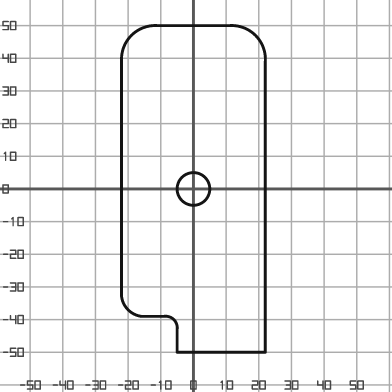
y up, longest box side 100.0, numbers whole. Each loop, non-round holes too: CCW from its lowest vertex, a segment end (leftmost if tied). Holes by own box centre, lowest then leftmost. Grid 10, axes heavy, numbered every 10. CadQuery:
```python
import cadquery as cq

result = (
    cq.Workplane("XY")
    .moveTo(-5.0, -50.0)
    .lineTo(22.0, -50.0)
    .lineTo(22.0, 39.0)
    .threePointArc((19.0, 47.0), (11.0, 50.0))
    .lineTo(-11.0, 50.0)
    .threePointArc((-19.0, 47.0), (-22.0, 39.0))
    .lineTo(-22.0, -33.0)
    .threePointArc((-20.0, -37.0), (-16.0, -39.0))
    .lineTo(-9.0, -39.0)
    .threePointArc((-6.0, -40.0), (-5.0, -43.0))
    .close()
    .moveTo(0.0, 0.0)
    .circle(5.0)
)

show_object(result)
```